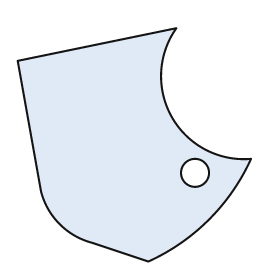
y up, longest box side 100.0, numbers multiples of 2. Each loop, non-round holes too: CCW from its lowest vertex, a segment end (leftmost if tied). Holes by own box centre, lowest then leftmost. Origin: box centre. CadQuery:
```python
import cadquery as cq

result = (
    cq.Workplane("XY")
    .moveTo(6.0, -50.0)
    .threePointArc((32.0, -32.0), (50.0, -6.0))
    .threePointArc((16.0, 12.0), (18.0, 50.0))
    .lineTo(-50.0, 36.0)
    .lineTo(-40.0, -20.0)
    .threePointArc((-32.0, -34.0), (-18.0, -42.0))
    .close()
    .moveTo(26.0, -12.0)
    .circle(6.0)
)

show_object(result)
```